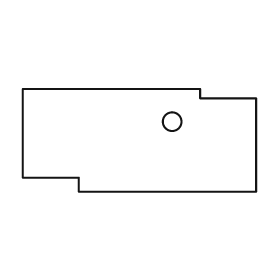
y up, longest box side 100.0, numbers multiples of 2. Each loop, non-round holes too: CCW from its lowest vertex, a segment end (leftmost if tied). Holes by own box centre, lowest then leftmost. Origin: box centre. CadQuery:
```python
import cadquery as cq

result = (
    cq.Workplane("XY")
    .moveTo(-26.0, -22.0)
    .lineTo(50.0, -22.0)
    .lineTo(50.0, 18.0)
    .lineTo(26.0, 18.0)
    .lineTo(26.0, 22.0)
    .lineTo(-50.0, 22.0)
    .lineTo(-50.0, -16.0)
    .lineTo(-26.0, -16.0)
    .close()
    .moveTo(14.0, 8.0)
    .circle(4.0)
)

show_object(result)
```